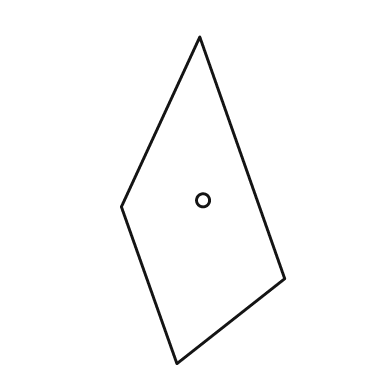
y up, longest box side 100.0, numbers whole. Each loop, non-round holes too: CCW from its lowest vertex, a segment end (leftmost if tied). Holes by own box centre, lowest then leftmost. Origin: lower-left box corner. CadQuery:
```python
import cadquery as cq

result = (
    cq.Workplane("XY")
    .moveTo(17.0, 0.0)
    .lineTo(50.0, 26.0)
    .lineTo(24.0, 100.0)
    .lineTo(0.0, 48.0)
    .close()
    .moveTo(25.0, 50.0)
    .circle(2.0)
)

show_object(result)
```